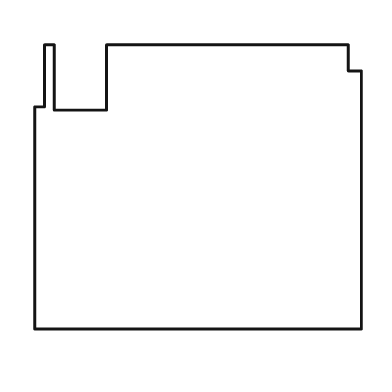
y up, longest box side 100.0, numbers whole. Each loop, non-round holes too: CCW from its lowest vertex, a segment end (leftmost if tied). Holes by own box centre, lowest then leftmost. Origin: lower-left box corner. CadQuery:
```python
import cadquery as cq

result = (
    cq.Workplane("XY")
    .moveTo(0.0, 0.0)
    .lineTo(100.0, 0.0)
    .lineTo(100.0, 79.0)
    .lineTo(96.0, 79.0)
    .lineTo(96.0, 87.0)
    .lineTo(22.0, 87.0)
    .lineTo(22.0, 67.0)
    .lineTo(6.0, 67.0)
    .lineTo(6.0, 87.0)
    .lineTo(3.0, 87.0)
    .lineTo(3.0, 68.0)
    .lineTo(0.0, 68.0)
    .close()
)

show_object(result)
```